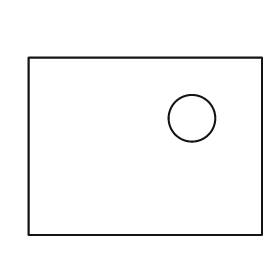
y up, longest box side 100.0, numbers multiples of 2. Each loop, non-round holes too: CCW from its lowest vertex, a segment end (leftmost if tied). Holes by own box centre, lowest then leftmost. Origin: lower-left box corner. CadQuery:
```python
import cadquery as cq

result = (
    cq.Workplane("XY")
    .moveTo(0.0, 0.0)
    .lineTo(100.0, 0.0)
    .lineTo(100.0, 76.0)
    .lineTo(0.0, 76.0)
    .close()
    .moveTo(70.0, 50.0)
    .circle(10.0)
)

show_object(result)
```